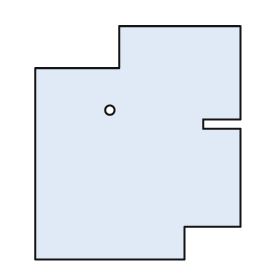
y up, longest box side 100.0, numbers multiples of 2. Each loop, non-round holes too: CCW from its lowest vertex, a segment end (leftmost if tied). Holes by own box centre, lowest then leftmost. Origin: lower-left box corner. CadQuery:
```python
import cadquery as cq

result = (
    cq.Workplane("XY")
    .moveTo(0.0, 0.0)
    .lineTo(64.0, 0.0)
    .lineTo(64.0, 14.0)
    .lineTo(88.0, 14.0)
    .lineTo(88.0, 56.0)
    .lineTo(72.0, 56.0)
    .lineTo(72.0, 60.0)
    .lineTo(88.0, 60.0)
    .lineTo(88.0, 100.0)
    .lineTo(36.0, 100.0)
    .lineTo(36.0, 82.0)
    .lineTo(0.0, 82.0)
    .close()
    .moveTo(32.0, 64.0)
    .circle(2.0)
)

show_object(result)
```